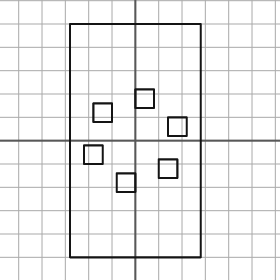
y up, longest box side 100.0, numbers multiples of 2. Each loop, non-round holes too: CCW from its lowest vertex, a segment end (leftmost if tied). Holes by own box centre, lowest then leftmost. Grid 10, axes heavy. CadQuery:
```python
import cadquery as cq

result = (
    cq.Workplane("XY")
    .moveTo(-28.0, -50.0)
    .lineTo(28.0, -50.0)
    .lineTo(28.0, 50.0)
    .lineTo(-28.0, 50.0)
    .close()
    .moveTo(-8.0, -22.0)
    .lineTo(0.0, -22.0)
    .lineTo(0.0, -14.0)
    .lineTo(-8.0, -14.0)
    .close()
    .moveTo(10.0, -16.0)
    .lineTo(18.0, -16.0)
    .lineTo(18.0, -8.0)
    .lineTo(10.0, -8.0)
    .close()
    .moveTo(-22.0, -10.0)
    .lineTo(-14.0, -10.0)
    .lineTo(-14.0, -2.0)
    .lineTo(-22.0, -2.0)
    .close()
    .moveTo(14.0, 2.0)
    .lineTo(22.0, 2.0)
    .lineTo(22.0, 10.0)
    .lineTo(14.0, 10.0)
    .close()
    .moveTo(-18.0, 8.0)
    .lineTo(-10.0, 8.0)
    .lineTo(-10.0, 16.0)
    .lineTo(-18.0, 16.0)
    .close()
    .moveTo(0.0, 14.0)
    .lineTo(8.0, 14.0)
    .lineTo(8.0, 22.0)
    .lineTo(0.0, 22.0)
    .close()
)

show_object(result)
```